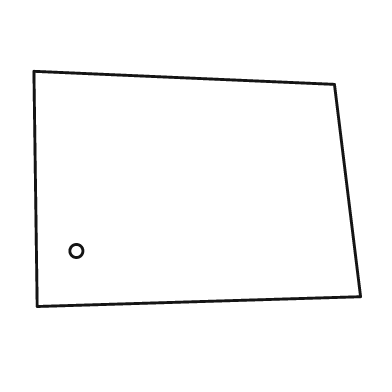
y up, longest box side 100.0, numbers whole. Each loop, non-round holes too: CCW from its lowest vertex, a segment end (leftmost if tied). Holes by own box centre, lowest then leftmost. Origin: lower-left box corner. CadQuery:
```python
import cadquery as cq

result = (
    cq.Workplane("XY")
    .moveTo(1.0, 0.0)
    .lineTo(100.0, 3.0)
    .lineTo(92.0, 68.0)
    .lineTo(0.0, 72.0)
    .close()
    .moveTo(13.0, 17.0)
    .circle(2.0)
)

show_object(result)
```